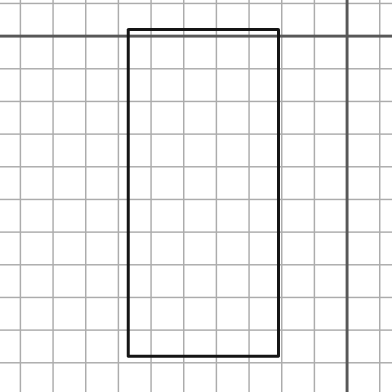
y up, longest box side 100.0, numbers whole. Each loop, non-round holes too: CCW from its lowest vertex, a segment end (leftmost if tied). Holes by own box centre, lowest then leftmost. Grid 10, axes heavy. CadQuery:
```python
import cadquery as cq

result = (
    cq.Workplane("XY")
    .moveTo(-67.0, -98.0)
    .lineTo(-21.0, -98.0)
    .lineTo(-21.0, 2.0)
    .lineTo(-67.0, 2.0)
    .close()
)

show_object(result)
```